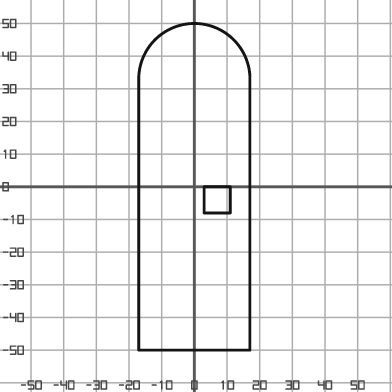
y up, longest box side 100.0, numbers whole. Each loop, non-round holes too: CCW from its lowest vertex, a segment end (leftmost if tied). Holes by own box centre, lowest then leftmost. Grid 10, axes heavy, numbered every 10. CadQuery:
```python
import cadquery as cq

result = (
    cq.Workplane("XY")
    .moveTo(-17.0, -50.0)
    .lineTo(17.0, -50.0)
    .lineTo(17.0, 34.0)
    .threePointArc((0.0, 50.0), (-17.0, 34.0))
    .close()
    .moveTo(3.0, -8.0)
    .lineTo(11.0, -8.0)
    .lineTo(11.0, 0.0)
    .lineTo(3.0, 0.0)
    .close()
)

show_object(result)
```